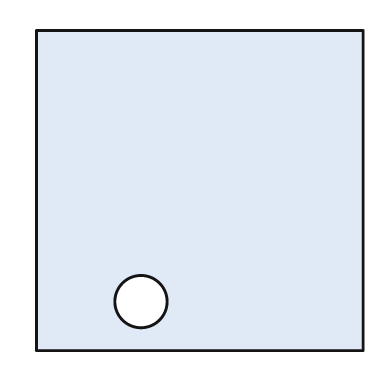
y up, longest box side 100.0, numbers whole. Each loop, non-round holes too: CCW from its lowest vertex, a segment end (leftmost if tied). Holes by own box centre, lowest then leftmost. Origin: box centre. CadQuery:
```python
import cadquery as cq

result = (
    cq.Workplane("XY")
    .moveTo(-50.0, -49.0)
    .lineTo(50.0, -49.0)
    .lineTo(50.0, 49.0)
    .lineTo(-50.0, 49.0)
    .close()
    .moveTo(-18.0, -34.0)
    .circle(8.0)
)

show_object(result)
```